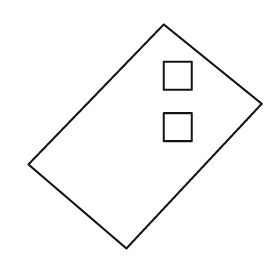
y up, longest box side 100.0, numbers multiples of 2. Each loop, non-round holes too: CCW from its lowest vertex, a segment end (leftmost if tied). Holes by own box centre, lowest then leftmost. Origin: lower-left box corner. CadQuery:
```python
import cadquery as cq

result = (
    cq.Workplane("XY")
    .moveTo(42.0, 0.0)
    .lineTo(100.0, 62.0)
    .lineTo(58.0, 96.0)
    .lineTo(0.0, 36.0)
    .close()
    .moveTo(58.0, 46.0)
    .lineTo(70.0, 46.0)
    .lineTo(70.0, 58.0)
    .lineTo(58.0, 58.0)
    .close()
    .moveTo(58.0, 68.0)
    .lineTo(70.0, 68.0)
    .lineTo(70.0, 80.0)
    .lineTo(58.0, 80.0)
    .close()
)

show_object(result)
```